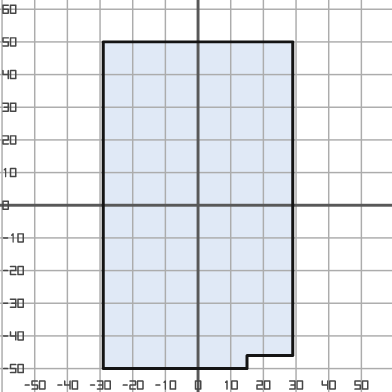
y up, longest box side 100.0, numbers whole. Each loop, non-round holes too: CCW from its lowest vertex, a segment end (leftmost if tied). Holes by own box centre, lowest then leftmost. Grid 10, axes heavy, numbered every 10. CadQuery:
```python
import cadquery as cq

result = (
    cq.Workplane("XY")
    .moveTo(-29.0, -50.0)
    .lineTo(15.0, -50.0)
    .lineTo(15.0, -46.0)
    .lineTo(29.0, -46.0)
    .lineTo(29.0, 50.0)
    .lineTo(-29.0, 50.0)
    .close()
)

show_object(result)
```